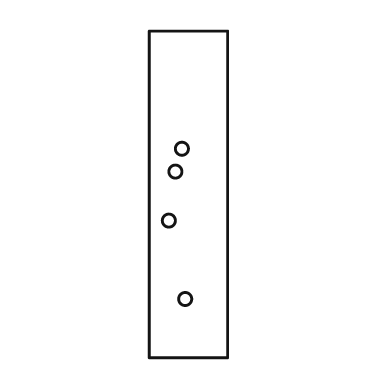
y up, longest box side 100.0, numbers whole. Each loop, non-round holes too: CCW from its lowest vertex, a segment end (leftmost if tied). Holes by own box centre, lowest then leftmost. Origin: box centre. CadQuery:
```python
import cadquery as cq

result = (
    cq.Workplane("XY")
    .moveTo(-12.0, -50.0)
    .lineTo(12.0, -50.0)
    .lineTo(12.0, 50.0)
    .lineTo(-12.0, 50.0)
    .close()
    .moveTo(-1.0, -32.0)
    .circle(2.0)
    .moveTo(-6.0, -8.0)
    .circle(2.0)
    .moveTo(-4.0, 7.0)
    .circle(2.0)
    .moveTo(-2.0, 14.0)
    .circle(2.0)
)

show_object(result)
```